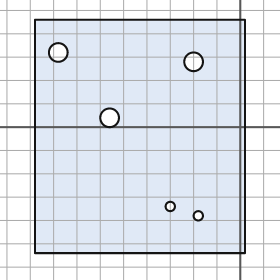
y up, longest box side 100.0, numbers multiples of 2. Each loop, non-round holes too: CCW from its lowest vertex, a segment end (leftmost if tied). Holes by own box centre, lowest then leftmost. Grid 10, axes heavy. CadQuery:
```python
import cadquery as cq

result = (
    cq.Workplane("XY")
    .moveTo(-88.0, -54.0)
    .lineTo(2.0, -54.0)
    .lineTo(2.0, 46.0)
    .lineTo(-88.0, 46.0)
    .close()
    .moveTo(-18.0, -38.0)
    .circle(2.0)
    .moveTo(-30.0, -34.0)
    .circle(2.0)
    .moveTo(-56.0, 4.0)
    .circle(4.0)
    .moveTo(-20.0, 28.0)
    .circle(4.0)
    .moveTo(-78.0, 32.0)
    .circle(4.0)
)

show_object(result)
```